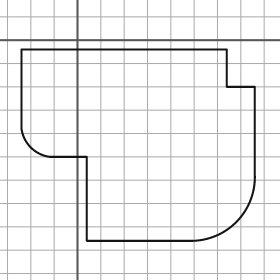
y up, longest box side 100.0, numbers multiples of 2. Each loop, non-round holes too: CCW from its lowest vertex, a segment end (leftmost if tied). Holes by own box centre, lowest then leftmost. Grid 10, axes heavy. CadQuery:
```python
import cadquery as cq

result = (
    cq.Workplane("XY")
    .moveTo(4.0, -86.0)
    .lineTo(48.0, -86.0)
    .threePointArc((68.0, -78.0), (76.0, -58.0))
    .lineTo(76.0, -20.0)
    .lineTo(64.0, -20.0)
    .lineTo(64.0, -4.0)
    .lineTo(-24.0, -4.0)
    .lineTo(-24.0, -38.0)
    .threePointArc((-20.0, -46.0), (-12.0, -50.0))
    .lineTo(4.0, -50.0)
    .close()
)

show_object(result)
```